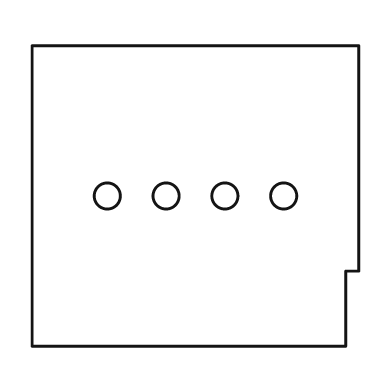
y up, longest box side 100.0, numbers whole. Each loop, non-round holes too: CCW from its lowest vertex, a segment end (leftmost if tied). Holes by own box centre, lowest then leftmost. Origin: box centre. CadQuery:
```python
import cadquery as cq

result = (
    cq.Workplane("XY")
    .moveTo(-50.0, -46.0)
    .lineTo(46.0, -46.0)
    .lineTo(46.0, -23.0)
    .lineTo(50.0, -23.0)
    .lineTo(50.0, 46.0)
    .lineTo(-50.0, 46.0)
    .close()
    .moveTo(-27.0, 0.0)
    .circle(4.0)
    .moveTo(-9.0, 0.0)
    .circle(4.0)
    .moveTo(9.0, 0.0)
    .circle(4.0)
    .moveTo(27.0, 0.0)
    .circle(4.0)
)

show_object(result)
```